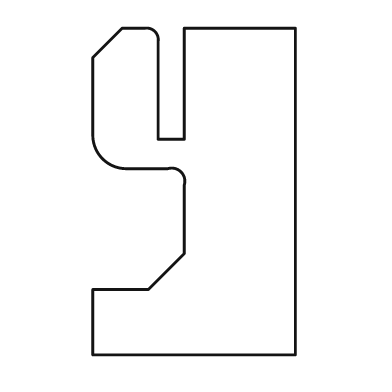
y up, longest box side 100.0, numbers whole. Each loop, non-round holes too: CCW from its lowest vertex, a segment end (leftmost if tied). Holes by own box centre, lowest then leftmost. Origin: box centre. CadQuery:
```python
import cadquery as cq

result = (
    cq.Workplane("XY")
    .moveTo(-31.0, -50.0)
    .lineTo(31.0, -50.0)
    .lineTo(31.0, 50.0)
    .lineTo(-3.0, 50.0)
    .lineTo(-3.0, 16.0)
    .lineTo(-11.0, 16.0)
    .lineTo(-11.0, 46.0)
    .threePointArc((-12.0, 49.0), (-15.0, 50.0))
    .lineTo(-22.0, 50.0)
    .lineTo(-31.0, 41.0)
    .lineTo(-31.0, 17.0)
    .threePointArc((-28.0, 10.0), (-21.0, 7.0))
    .lineTo(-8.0, 7.0)
    .threePointArc((-4.0, 6.0), (-3.0, 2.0))
    .lineTo(-3.0, -19.0)
    .lineTo(-14.0, -30.0)
    .lineTo(-31.0, -30.0)
    .close()
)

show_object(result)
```